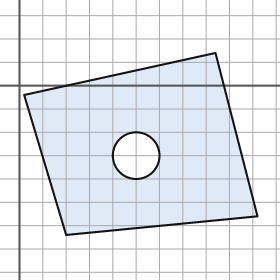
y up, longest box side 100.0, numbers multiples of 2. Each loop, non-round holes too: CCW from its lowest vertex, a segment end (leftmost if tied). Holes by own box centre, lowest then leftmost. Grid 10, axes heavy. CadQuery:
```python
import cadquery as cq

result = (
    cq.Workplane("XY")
    .moveTo(20.0, -64.0)
    .lineTo(102.0, -56.0)
    .lineTo(84.0, 14.0)
    .lineTo(2.0, -4.0)
    .close()
    .moveTo(50.0, -30.0)
    .circle(10.0)
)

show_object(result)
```